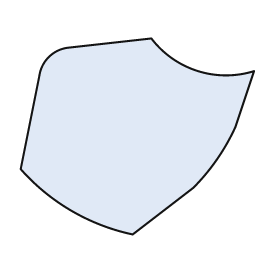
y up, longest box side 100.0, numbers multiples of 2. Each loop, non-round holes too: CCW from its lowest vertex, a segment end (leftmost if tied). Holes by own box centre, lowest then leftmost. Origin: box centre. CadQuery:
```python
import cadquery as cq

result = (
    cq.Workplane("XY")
    .moveTo(-2.0, -42.0)
    .lineTo(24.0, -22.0)
    .threePointArc((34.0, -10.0), (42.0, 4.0))
    .lineTo(50.0, 28.0)
    .threePointArc((26.0, 28.0), (6.0, 42.0))
    .lineTo(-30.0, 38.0)
    .threePointArc((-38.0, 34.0), (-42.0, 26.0))
    .lineTo(-50.0, -14.0)
    .threePointArc((-28.0, -32.0), (-2.0, -42.0))
    .close()
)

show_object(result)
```